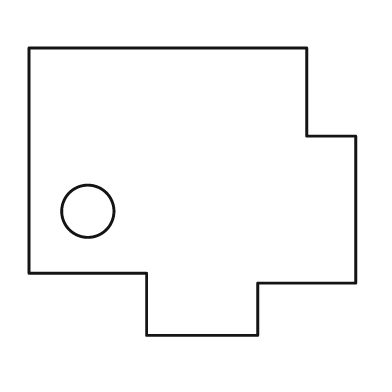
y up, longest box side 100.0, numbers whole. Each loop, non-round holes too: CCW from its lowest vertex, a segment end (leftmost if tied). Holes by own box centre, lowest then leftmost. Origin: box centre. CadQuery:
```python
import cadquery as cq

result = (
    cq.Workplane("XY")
    .moveTo(-14.0, -44.0)
    .lineTo(20.0, -44.0)
    .lineTo(20.0, -28.0)
    .lineTo(50.0, -28.0)
    .lineTo(50.0, 17.0)
    .lineTo(35.0, 17.0)
    .lineTo(35.0, 44.0)
    .lineTo(-50.0, 44.0)
    .lineTo(-50.0, -25.0)
    .lineTo(-14.0, -25.0)
    .close()
    .moveTo(-32.0, -6.0)
    .circle(8.0)
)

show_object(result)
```